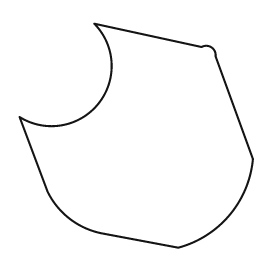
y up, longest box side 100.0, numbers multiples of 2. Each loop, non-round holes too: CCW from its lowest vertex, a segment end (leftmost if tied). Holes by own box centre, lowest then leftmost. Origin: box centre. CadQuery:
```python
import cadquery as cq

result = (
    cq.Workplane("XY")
    .moveTo(18.0, -48.0)
    .threePointArc((40.0, -34.0), (50.0, -10.0))
    .lineTo(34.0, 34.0)
    .threePointArc((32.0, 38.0), (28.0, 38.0))
    .lineTo(-18.0, 48.0)
    .threePointArc((-16.0, 14.0), (-50.0, 8.0))
    .lineTo(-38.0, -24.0)
    .threePointArc((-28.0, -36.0), (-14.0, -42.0))
    .close()
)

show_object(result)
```